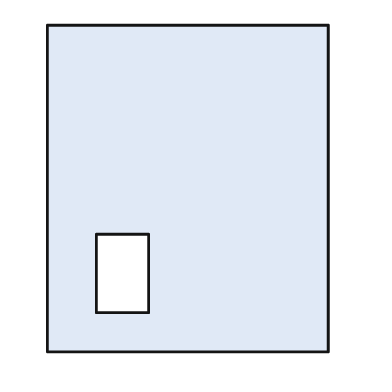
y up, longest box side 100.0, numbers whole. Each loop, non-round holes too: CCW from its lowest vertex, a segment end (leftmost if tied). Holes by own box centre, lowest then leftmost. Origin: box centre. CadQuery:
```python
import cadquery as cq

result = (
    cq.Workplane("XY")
    .moveTo(-43.0, -50.0)
    .lineTo(43.0, -50.0)
    .lineTo(43.0, 50.0)
    .lineTo(-43.0, 50.0)
    .close()
    .moveTo(-28.0, -38.0)
    .lineTo(-12.0, -38.0)
    .lineTo(-12.0, -14.0)
    .lineTo(-28.0, -14.0)
    .close()
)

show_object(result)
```